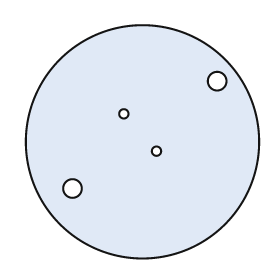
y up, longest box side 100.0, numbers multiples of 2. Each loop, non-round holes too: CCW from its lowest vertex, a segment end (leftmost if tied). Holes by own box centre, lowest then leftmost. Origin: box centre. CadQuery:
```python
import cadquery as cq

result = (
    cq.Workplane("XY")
    .moveTo(0.0, 0.0)
    .circle(50.0)
    .moveTo(-30.0, -20.0)
    .circle(4.0)
    .moveTo(6.0, -4.0)
    .circle(2.0)
    .moveTo(-8.0, 12.0)
    .circle(2.0)
    .moveTo(32.0, 26.0)
    .circle(4.0)
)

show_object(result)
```